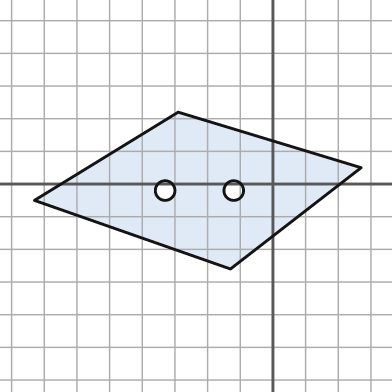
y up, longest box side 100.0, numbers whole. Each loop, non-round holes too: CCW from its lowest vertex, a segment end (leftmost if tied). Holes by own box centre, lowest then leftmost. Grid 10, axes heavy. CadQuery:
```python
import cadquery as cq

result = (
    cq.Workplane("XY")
    .moveTo(-13.0, -26.0)
    .lineTo(27.0, 5.0)
    .lineTo(-29.0, 22.0)
    .lineTo(-73.0, -5.0)
    .close()
    .moveTo(-33.0, -2.0)
    .circle(3.0)
    .moveTo(-12.0, -2.0)
    .circle(3.0)
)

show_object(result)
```